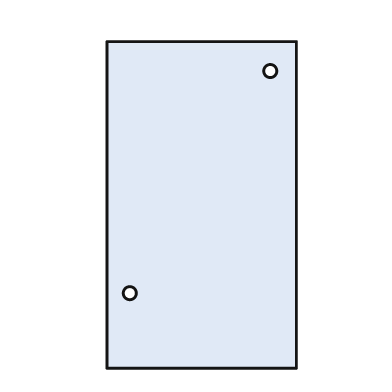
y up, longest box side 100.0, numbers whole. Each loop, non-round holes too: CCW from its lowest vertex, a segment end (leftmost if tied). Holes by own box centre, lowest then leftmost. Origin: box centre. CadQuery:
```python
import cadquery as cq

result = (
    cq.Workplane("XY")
    .moveTo(-29.0, -50.0)
    .lineTo(29.0, -50.0)
    .lineTo(29.0, 50.0)
    .lineTo(-29.0, 50.0)
    .close()
    .moveTo(-22.0, -27.0)
    .circle(2.0)
    .moveTo(21.0, 41.0)
    .circle(2.0)
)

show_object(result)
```